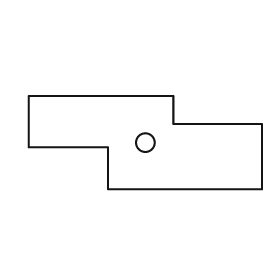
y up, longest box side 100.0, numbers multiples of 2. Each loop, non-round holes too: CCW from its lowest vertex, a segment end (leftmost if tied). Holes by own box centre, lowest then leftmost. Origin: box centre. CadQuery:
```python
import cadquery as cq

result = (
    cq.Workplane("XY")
    .moveTo(-16.0, -20.0)
    .lineTo(50.0, -20.0)
    .lineTo(50.0, 8.0)
    .lineTo(12.0, 8.0)
    .lineTo(12.0, 20.0)
    .lineTo(-50.0, 20.0)
    .lineTo(-50.0, -2.0)
    .lineTo(-16.0, -2.0)
    .close()
    .moveTo(0.0, 0.0)
    .circle(4.0)
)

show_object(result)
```